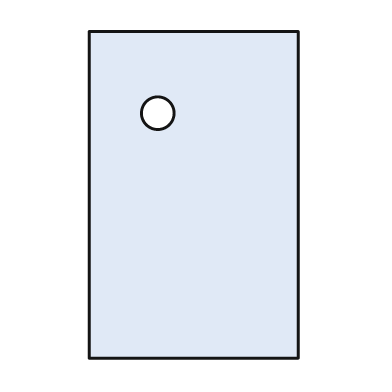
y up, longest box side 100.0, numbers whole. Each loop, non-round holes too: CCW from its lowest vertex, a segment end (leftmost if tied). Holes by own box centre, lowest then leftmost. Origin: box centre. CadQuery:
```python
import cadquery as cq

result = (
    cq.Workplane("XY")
    .moveTo(-32.0, -50.0)
    .lineTo(32.0, -50.0)
    .lineTo(32.0, 50.0)
    .lineTo(-32.0, 50.0)
    .close()
    .moveTo(-11.0, 25.0)
    .circle(5.0)
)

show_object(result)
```